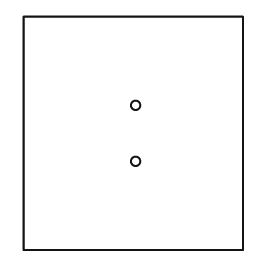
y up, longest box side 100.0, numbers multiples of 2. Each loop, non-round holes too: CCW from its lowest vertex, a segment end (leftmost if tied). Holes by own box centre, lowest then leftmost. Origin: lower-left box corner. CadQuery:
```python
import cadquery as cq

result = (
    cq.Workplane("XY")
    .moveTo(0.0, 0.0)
    .lineTo(94.0, 0.0)
    .lineTo(94.0, 100.0)
    .lineTo(0.0, 100.0)
    .close()
    .moveTo(48.0, 38.0)
    .circle(2.0)
    .moveTo(48.0, 62.0)
    .circle(2.0)
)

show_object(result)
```